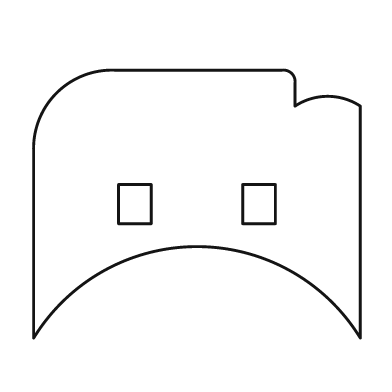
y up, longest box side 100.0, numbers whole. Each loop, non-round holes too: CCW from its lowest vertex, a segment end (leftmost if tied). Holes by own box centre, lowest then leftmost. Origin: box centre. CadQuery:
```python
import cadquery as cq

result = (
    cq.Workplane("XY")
    .moveTo(-50.0, -41.0)
    .threePointArc((0.0, -13.0), (50.0, -41.0))
    .lineTo(50.0, 30.0)
    .threePointArc((40.0, 33.0), (30.0, 30.0))
    .lineTo(30.0, 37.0)
    .threePointArc((29.0, 40.0), (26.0, 41.0))
    .lineTo(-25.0, 41.0)
    .threePointArc((-43.0, 34.0), (-50.0, 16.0))
    .close()
    .moveTo(-24.0, -6.0)
    .lineTo(-14.0, -6.0)
    .lineTo(-14.0, 6.0)
    .lineTo(-24.0, 6.0)
    .close()
    .moveTo(14.0, -6.0)
    .lineTo(24.0, -6.0)
    .lineTo(24.0, 6.0)
    .lineTo(14.0, 6.0)
    .close()
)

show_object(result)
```